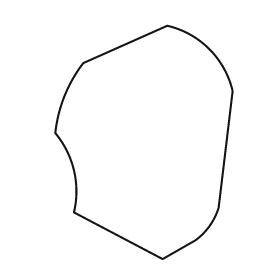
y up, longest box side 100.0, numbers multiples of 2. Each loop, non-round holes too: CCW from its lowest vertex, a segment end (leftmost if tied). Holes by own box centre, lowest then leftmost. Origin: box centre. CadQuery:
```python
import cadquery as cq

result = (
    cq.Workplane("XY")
    .moveTo(8.0, -50.0)
    .lineTo(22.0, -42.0)
    .threePointArc((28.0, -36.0), (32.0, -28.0))
    .lineTo(38.0, 22.0)
    .threePointArc((28.0, 40.0), (10.0, 50.0))
    .lineTo(-26.0, 34.0)
    .threePointArc((-34.0, 20.0), (-38.0, 4.0))
    .threePointArc((-30.0, -12.0), (-30.0, -30.0))
    .close()
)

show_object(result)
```